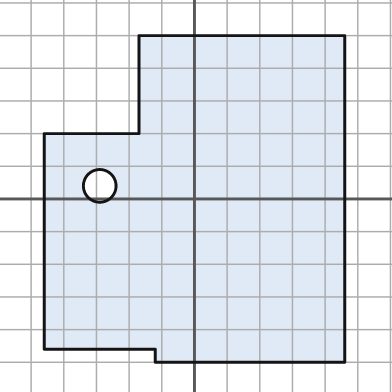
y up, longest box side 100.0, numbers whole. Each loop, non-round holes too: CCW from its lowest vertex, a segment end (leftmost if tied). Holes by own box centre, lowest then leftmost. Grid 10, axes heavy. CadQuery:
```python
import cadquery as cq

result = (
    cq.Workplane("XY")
    .moveTo(-12.0, -50.0)
    .lineTo(46.0, -50.0)
    .lineTo(46.0, 50.0)
    .lineTo(-17.0, 50.0)
    .lineTo(-17.0, 20.0)
    .lineTo(-46.0, 20.0)
    .lineTo(-46.0, -46.0)
    .lineTo(-12.0, -46.0)
    .close()
    .moveTo(-29.0, 4.0)
    .circle(5.0)
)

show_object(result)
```